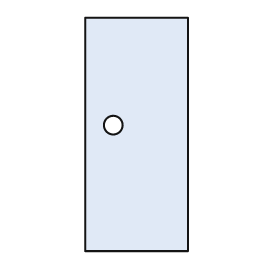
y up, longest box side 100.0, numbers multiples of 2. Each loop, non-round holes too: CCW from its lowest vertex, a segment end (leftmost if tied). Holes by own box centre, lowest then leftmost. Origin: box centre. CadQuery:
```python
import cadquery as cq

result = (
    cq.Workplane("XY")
    .moveTo(-22.0, -50.0)
    .lineTo(22.0, -50.0)
    .lineTo(22.0, 50.0)
    .lineTo(-22.0, 50.0)
    .close()
    .moveTo(-10.0, 4.0)
    .circle(4.0)
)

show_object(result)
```